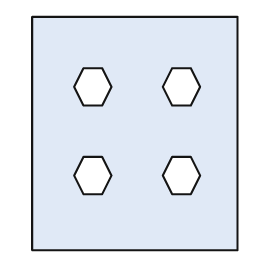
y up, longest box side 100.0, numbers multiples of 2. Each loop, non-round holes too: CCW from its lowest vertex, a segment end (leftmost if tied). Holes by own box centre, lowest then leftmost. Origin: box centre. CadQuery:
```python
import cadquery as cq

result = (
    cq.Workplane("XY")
    .moveTo(-44.0, -50.0)
    .lineTo(44.0, -50.0)
    .lineTo(44.0, 50.0)
    .lineTo(-44.0, 50.0)
    .close()
    .moveTo(-22.0, -26.0)
    .lineTo(-14.0, -26.0)
    .lineTo(-10.0, -18.0)
    .lineTo(-14.0, -10.0)
    .lineTo(-22.0, -10.0)
    .lineTo(-26.0, -18.0)
    .close()
    .moveTo(16.0, -26.0)
    .lineTo(24.0, -26.0)
    .lineTo(28.0, -18.0)
    .lineTo(24.0, -10.0)
    .lineTo(16.0, -10.0)
    .lineTo(12.0, -18.0)
    .close()
    .moveTo(-22.0, 12.0)
    .lineTo(-14.0, 12.0)
    .lineTo(-10.0, 20.0)
    .lineTo(-14.0, 28.0)
    .lineTo(-22.0, 28.0)
    .lineTo(-26.0, 20.0)
    .close()
    .moveTo(16.0, 12.0)
    .lineTo(24.0, 12.0)
    .lineTo(28.0, 20.0)
    .lineTo(24.0, 28.0)
    .lineTo(16.0, 28.0)
    .lineTo(12.0, 20.0)
    .close()
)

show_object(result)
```